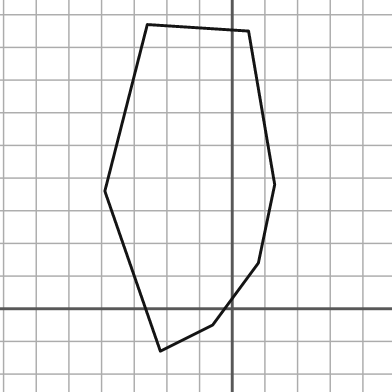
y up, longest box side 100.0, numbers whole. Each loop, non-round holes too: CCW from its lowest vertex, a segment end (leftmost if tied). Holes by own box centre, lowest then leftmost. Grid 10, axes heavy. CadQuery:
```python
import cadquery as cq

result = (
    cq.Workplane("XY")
    .moveTo(-22.0, -13.0)
    .lineTo(-6.0, -5.0)
    .lineTo(8.0, 14.0)
    .lineTo(13.0, 38.0)
    .lineTo(5.0, 85.0)
    .lineTo(-26.0, 87.0)
    .lineTo(-39.0, 36.0)
    .close()
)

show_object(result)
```